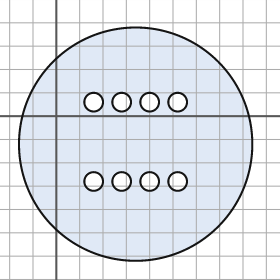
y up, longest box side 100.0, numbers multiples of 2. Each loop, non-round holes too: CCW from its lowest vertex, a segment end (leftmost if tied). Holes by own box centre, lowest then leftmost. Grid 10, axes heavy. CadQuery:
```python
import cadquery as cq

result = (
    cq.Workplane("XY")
    .moveTo(34.0, -12.0)
    .circle(50.0)
    .moveTo(16.0, -28.0)
    .circle(4.0)
    .moveTo(28.0, -28.0)
    .circle(4.0)
    .moveTo(40.0, -28.0)
    .circle(4.0)
    .moveTo(52.0, -28.0)
    .circle(4.0)
    .moveTo(16.0, 6.0)
    .circle(4.0)
    .moveTo(28.0, 6.0)
    .circle(4.0)
    .moveTo(40.0, 6.0)
    .circle(4.0)
    .moveTo(52.0, 6.0)
    .circle(4.0)
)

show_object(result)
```